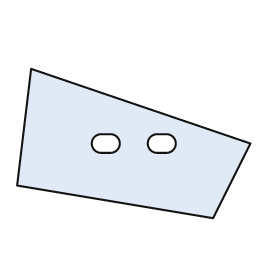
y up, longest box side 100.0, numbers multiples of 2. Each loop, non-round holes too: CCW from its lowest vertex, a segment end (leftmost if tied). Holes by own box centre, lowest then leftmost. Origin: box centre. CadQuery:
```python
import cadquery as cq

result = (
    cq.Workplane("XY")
    .moveTo(34.0, -32.0)
    .lineTo(50.0, 0.0)
    .lineTo(-44.0, 32.0)
    .lineTo(-50.0, -18.0)
    .close()
    .moveTo(-14.0, -4.0)
    .lineTo(-10.0, -4.0)
    .threePointArc((-6.0, 0.0), (-10.0, 4.0))
    .lineTo(-14.0, 4.0)
    .threePointArc((-18.0, 0.0), (-14.0, -4.0))
    .close()
    .moveTo(10.0, -4.0)
    .lineTo(14.0, -4.0)
    .threePointArc((18.0, 0.0), (14.0, 4.0))
    .lineTo(10.0, 4.0)
    .threePointArc((6.0, 0.0), (10.0, -4.0))
    .close()
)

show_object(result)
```